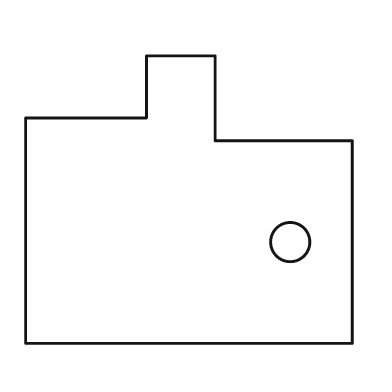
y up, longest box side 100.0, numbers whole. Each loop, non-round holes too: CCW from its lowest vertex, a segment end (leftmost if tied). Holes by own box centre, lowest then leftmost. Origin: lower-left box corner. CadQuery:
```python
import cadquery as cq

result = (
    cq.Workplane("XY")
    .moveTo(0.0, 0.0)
    .lineTo(100.0, 0.0)
    .lineTo(100.0, 62.0)
    .lineTo(58.0, 62.0)
    .lineTo(58.0, 88.0)
    .lineTo(37.0, 88.0)
    .lineTo(37.0, 69.0)
    .lineTo(0.0, 69.0)
    .close()
    .moveTo(81.0, 31.0)
    .circle(6.0)
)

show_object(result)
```